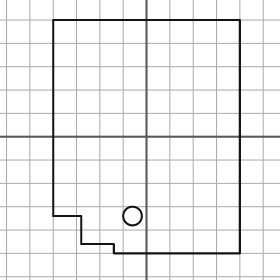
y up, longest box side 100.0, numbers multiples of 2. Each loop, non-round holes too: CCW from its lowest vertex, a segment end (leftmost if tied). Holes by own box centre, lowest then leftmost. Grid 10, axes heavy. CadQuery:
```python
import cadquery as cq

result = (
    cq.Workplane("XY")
    .moveTo(-14.0, -50.0)
    .lineTo(40.0, -50.0)
    .lineTo(40.0, 50.0)
    .lineTo(-40.0, 50.0)
    .lineTo(-40.0, -34.0)
    .lineTo(-28.0, -34.0)
    .lineTo(-28.0, -46.0)
    .lineTo(-14.0, -46.0)
    .close()
    .moveTo(-6.0, -34.0)
    .circle(4.0)
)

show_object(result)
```